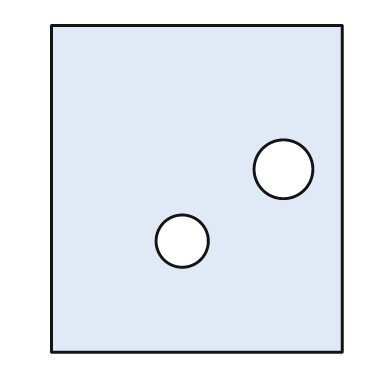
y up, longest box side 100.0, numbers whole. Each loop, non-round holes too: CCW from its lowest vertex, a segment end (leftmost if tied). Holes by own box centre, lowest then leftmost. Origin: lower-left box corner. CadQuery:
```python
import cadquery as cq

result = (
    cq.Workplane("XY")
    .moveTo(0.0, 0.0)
    .lineTo(89.0, 0.0)
    .lineTo(89.0, 100.0)
    .lineTo(0.0, 100.0)
    .close()
    .moveTo(40.0, 34.0)
    .circle(8.0)
    .moveTo(71.0, 56.0)
    .circle(9.0)
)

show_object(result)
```